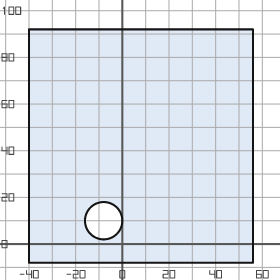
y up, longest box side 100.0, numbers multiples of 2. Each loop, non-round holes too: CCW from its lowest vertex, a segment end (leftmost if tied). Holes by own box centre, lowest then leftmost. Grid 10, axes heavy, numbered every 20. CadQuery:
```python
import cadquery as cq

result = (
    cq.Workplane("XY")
    .moveTo(-40.0, -8.0)
    .lineTo(56.0, -8.0)
    .lineTo(56.0, 92.0)
    .lineTo(-40.0, 92.0)
    .close()
    .moveTo(-8.0, 10.0)
    .circle(8.0)
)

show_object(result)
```